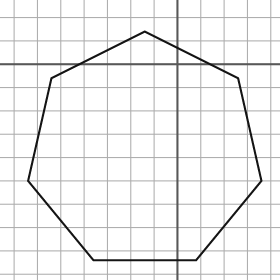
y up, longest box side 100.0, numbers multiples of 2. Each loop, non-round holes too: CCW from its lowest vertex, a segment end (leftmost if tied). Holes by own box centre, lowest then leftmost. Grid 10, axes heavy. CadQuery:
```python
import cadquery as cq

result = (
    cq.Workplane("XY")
    .moveTo(-36.0, -84.0)
    .lineTo(8.0, -84.0)
    .lineTo(36.0, -50.0)
    .lineTo(26.0, -6.0)
    .lineTo(-14.0, 14.0)
    .lineTo(-54.0, -6.0)
    .lineTo(-64.0, -50.0)
    .close()
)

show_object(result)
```